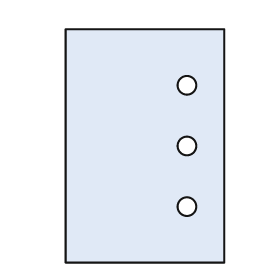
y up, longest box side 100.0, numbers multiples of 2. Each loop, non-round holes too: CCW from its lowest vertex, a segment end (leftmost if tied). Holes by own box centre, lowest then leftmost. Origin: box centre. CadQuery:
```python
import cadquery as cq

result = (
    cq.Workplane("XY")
    .moveTo(-34.0, -50.0)
    .lineTo(34.0, -50.0)
    .lineTo(34.0, 50.0)
    .lineTo(-34.0, 50.0)
    .close()
    .moveTo(18.0, -26.0)
    .circle(4.0)
    .moveTo(18.0, 0.0)
    .circle(4.0)
    .moveTo(18.0, 26.0)
    .circle(4.0)
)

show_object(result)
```